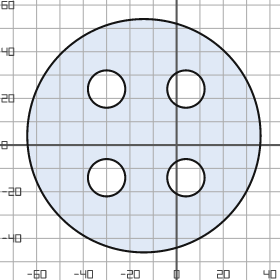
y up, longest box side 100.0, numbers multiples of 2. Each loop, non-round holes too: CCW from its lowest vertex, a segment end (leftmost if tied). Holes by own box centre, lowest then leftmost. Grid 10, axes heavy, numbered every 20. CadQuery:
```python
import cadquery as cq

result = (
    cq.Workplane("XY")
    .moveTo(-14.0, 4.0)
    .circle(50.0)
    .moveTo(-30.0, -14.0)
    .circle(8.0)
    .moveTo(4.0, -14.0)
    .circle(8.0)
    .moveTo(-30.0, 24.0)
    .circle(8.0)
    .moveTo(4.0, 24.0)
    .circle(8.0)
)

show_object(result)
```